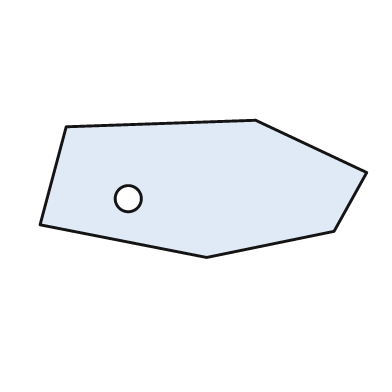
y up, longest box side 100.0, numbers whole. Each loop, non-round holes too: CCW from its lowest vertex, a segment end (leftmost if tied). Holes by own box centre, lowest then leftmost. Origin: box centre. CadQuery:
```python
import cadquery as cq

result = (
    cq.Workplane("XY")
    .moveTo(1.0, -21.0)
    .lineTo(40.0, -13.0)
    .lineTo(50.0, 5.0)
    .lineTo(16.0, 21.0)
    .lineTo(-42.0, 19.0)
    .lineTo(-50.0, -11.0)
    .close()
    .moveTo(-23.0, -3.0)
    .circle(4.0)
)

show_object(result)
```